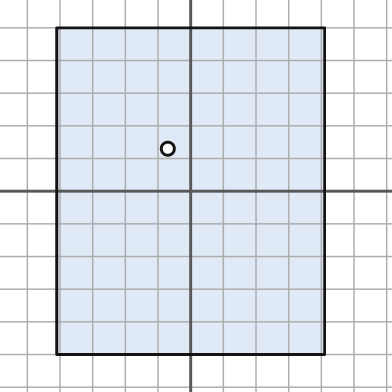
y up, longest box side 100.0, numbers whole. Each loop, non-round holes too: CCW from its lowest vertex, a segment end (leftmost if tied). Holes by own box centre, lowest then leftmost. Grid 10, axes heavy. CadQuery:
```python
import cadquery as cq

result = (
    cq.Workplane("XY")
    .moveTo(-41.0, -50.0)
    .lineTo(41.0, -50.0)
    .lineTo(41.0, 50.0)
    .lineTo(-41.0, 50.0)
    .close()
    .moveTo(-7.0, 13.0)
    .circle(2.0)
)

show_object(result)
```